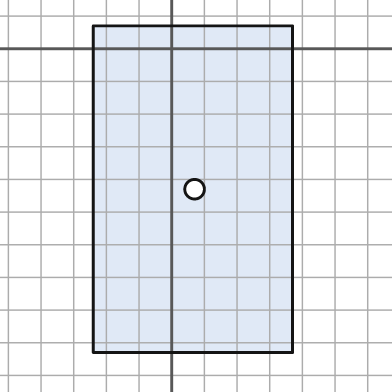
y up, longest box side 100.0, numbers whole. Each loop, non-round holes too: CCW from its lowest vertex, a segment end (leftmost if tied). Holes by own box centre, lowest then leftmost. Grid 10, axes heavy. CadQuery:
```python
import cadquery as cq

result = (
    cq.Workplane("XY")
    .moveTo(-24.0, -93.0)
    .lineTo(37.0, -93.0)
    .lineTo(37.0, 7.0)
    .lineTo(-24.0, 7.0)
    .close()
    .moveTo(7.0, -43.0)
    .circle(3.0)
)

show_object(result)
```